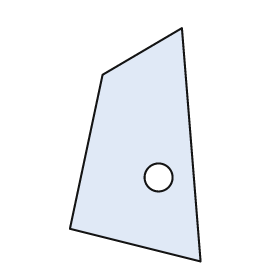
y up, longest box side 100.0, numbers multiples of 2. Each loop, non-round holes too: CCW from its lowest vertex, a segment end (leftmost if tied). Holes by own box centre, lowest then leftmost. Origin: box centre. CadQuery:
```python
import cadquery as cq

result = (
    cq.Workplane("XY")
    .moveTo(28.0, -50.0)
    .lineTo(20.0, 50.0)
    .lineTo(-14.0, 30.0)
    .lineTo(-28.0, -36.0)
    .close()
    .moveTo(10.0, -14.0)
    .circle(6.0)
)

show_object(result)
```